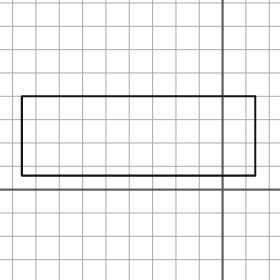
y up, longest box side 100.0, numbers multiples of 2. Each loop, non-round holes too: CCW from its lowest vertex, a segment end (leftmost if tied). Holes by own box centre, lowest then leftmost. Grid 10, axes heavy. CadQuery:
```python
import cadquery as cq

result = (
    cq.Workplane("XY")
    .moveTo(-86.0, 6.0)
    .lineTo(14.0, 6.0)
    .lineTo(14.0, 40.0)
    .lineTo(-86.0, 40.0)
    .close()
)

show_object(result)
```